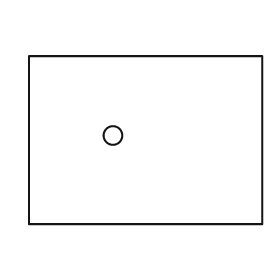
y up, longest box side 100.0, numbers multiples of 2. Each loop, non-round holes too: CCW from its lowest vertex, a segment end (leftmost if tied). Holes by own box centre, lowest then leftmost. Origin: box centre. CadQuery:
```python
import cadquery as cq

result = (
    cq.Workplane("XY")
    .moveTo(-50.0, -36.0)
    .lineTo(50.0, -36.0)
    .lineTo(50.0, 36.0)
    .lineTo(-50.0, 36.0)
    .close()
    .moveTo(-14.0, 2.0)
    .circle(4.0)
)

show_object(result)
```